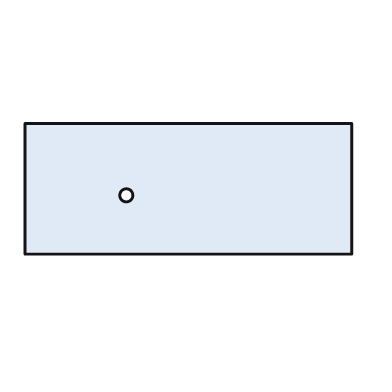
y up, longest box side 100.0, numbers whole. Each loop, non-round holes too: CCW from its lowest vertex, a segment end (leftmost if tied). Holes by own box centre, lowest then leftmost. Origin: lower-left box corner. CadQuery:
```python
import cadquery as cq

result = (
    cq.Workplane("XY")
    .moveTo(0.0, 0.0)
    .lineTo(100.0, 0.0)
    .lineTo(100.0, 40.0)
    .lineTo(0.0, 40.0)
    .close()
    .moveTo(31.0, 18.0)
    .circle(2.0)
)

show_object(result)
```